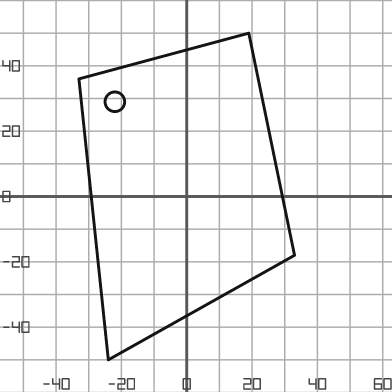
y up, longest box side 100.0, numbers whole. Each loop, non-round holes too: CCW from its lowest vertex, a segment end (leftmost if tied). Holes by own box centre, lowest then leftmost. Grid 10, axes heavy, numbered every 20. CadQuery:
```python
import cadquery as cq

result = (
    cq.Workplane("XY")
    .moveTo(-24.0, -50.0)
    .lineTo(33.0, -18.0)
    .lineTo(19.0, 50.0)
    .lineTo(-33.0, 36.0)
    .close()
    .moveTo(-22.0, 29.0)
    .circle(3.0)
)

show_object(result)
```